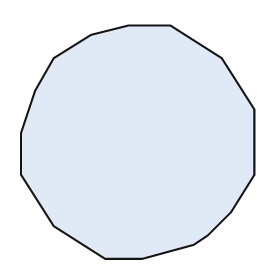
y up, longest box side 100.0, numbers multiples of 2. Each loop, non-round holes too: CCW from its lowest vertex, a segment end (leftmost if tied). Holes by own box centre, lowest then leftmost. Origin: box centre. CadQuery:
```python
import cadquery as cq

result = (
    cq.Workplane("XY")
    .moveTo(-14.0, -50.0)
    .lineTo(2.0, -50.0)
    .lineTo(24.0, -44.0)
    .lineTo(30.0, -40.0)
    .lineTo(40.0, -30.0)
    .lineTo(50.0, -14.0)
    .lineTo(50.0, 14.0)
    .lineTo(36.0, 36.0)
    .lineTo(14.0, 50.0)
    .lineTo(-4.0, 50.0)
    .lineTo(-20.0, 46.0)
    .lineTo(-36.0, 36.0)
    .lineTo(-44.0, 22.0)
    .lineTo(-50.0, 4.0)
    .lineTo(-50.0, -14.0)
    .lineTo(-36.0, -36.0)
    .close()
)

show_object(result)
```